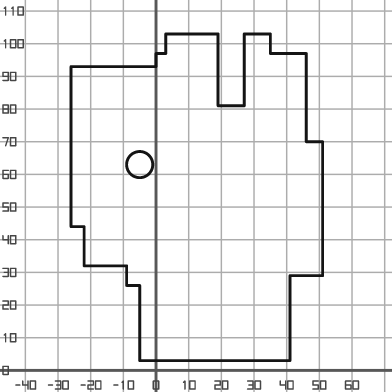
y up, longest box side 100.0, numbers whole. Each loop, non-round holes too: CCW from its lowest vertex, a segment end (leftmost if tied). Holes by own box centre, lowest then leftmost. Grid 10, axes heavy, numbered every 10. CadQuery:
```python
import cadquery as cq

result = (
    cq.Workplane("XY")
    .moveTo(-5.0, 3.0)
    .lineTo(41.0, 3.0)
    .lineTo(41.0, 29.0)
    .lineTo(51.0, 29.0)
    .lineTo(51.0, 70.0)
    .lineTo(46.0, 70.0)
    .lineTo(46.0, 97.0)
    .lineTo(35.0, 97.0)
    .lineTo(35.0, 103.0)
    .lineTo(27.0, 103.0)
    .lineTo(27.0, 81.0)
    .lineTo(19.0, 81.0)
    .lineTo(19.0, 103.0)
    .lineTo(3.0, 103.0)
    .lineTo(3.0, 97.0)
    .lineTo(0.0, 97.0)
    .lineTo(0.0, 93.0)
    .lineTo(-26.0, 93.0)
    .lineTo(-26.0, 44.0)
    .lineTo(-22.0, 44.0)
    .lineTo(-22.0, 32.0)
    .lineTo(-9.0, 32.0)
    .lineTo(-9.0, 26.0)
    .lineTo(-5.0, 26.0)
    .close()
    .moveTo(-5.0, 63.0)
    .circle(4.0)
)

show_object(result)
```